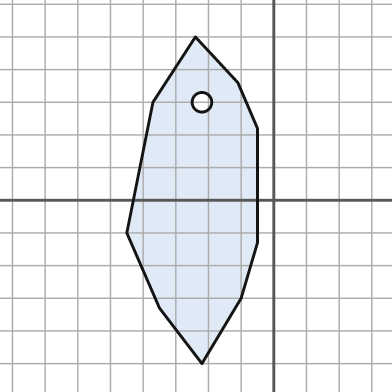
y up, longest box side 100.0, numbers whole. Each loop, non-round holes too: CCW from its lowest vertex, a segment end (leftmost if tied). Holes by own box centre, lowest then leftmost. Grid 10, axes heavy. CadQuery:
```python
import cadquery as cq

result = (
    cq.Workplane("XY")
    .moveTo(-22.0, -50.0)
    .lineTo(-10.0, -30.0)
    .lineTo(-5.0, -13.0)
    .lineTo(-5.0, 22.0)
    .lineTo(-11.0, 36.0)
    .lineTo(-24.0, 50.0)
    .lineTo(-37.0, 30.0)
    .lineTo(-45.0, -10.0)
    .lineTo(-35.0, -33.0)
    .close()
    .moveTo(-22.0, 30.0)
    .circle(3.0)
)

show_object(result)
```